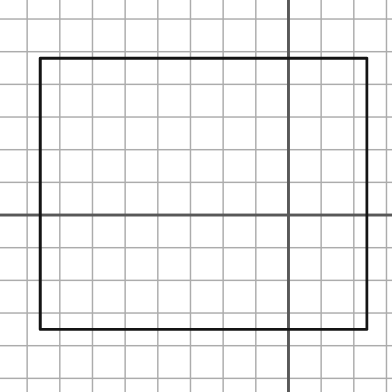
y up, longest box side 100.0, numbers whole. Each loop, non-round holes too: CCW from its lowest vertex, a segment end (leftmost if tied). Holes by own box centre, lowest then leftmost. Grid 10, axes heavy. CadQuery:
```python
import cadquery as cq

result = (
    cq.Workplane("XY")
    .moveTo(-76.0, -35.0)
    .lineTo(24.0, -35.0)
    .lineTo(24.0, 48.0)
    .lineTo(-76.0, 48.0)
    .close()
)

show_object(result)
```